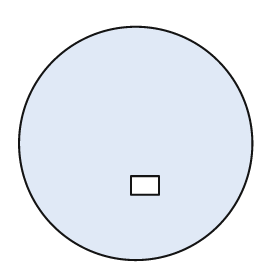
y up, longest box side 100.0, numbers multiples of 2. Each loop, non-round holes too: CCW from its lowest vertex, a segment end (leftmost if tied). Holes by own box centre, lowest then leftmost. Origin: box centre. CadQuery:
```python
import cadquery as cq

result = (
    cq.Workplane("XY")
    .moveTo(0.0, 0.0)
    .circle(50.0)
    .moveTo(-2.0, -22.0)
    .lineTo(10.0, -22.0)
    .lineTo(10.0, -14.0)
    .lineTo(-2.0, -14.0)
    .close()
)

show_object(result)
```